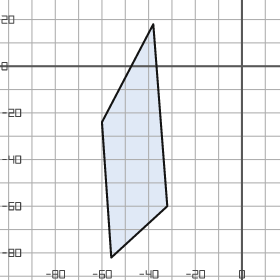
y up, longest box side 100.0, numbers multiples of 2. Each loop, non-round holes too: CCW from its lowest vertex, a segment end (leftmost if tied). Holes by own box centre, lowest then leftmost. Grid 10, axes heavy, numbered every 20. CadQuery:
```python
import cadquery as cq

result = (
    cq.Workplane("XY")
    .moveTo(-56.0, -82.0)
    .lineTo(-32.0, -60.0)
    .lineTo(-38.0, 18.0)
    .lineTo(-60.0, -24.0)
    .close()
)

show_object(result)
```